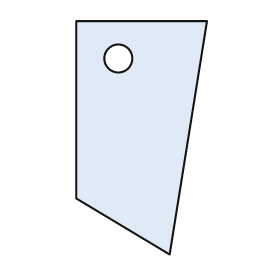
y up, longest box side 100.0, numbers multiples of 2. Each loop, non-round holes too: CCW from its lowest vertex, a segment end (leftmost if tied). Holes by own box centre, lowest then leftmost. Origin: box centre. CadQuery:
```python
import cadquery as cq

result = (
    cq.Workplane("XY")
    .moveTo(12.0, -50.0)
    .lineTo(28.0, 50.0)
    .lineTo(-28.0, 50.0)
    .lineTo(-28.0, -26.0)
    .close()
    .moveTo(-10.0, 34.0)
    .circle(6.0)
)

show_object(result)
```